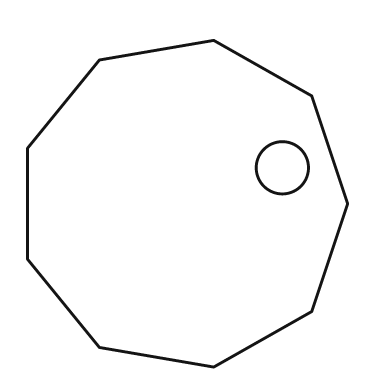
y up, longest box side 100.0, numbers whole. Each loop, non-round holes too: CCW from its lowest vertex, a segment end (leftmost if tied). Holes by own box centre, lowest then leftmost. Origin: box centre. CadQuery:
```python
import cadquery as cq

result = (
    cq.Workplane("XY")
    .moveTo(8.0, -50.0)
    .lineTo(38.0, -33.0)
    .lineTo(49.0, 0.0)
    .lineTo(38.0, 33.0)
    .lineTo(8.0, 50.0)
    .lineTo(-27.0, 44.0)
    .lineTo(-49.0, 17.0)
    .lineTo(-49.0, -17.0)
    .lineTo(-27.0, -44.0)
    .close()
    .moveTo(29.0, 11.0)
    .circle(8.0)
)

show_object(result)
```